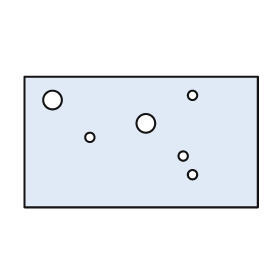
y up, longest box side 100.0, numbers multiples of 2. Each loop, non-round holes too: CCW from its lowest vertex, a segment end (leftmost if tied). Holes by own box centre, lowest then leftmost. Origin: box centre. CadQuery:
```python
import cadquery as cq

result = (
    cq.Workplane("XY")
    .moveTo(-50.0, -28.0)
    .lineTo(50.0, -28.0)
    .lineTo(50.0, 28.0)
    .lineTo(-50.0, 28.0)
    .close()
    .moveTo(22.0, -14.0)
    .circle(2.0)
    .moveTo(18.0, -6.0)
    .circle(2.0)
    .moveTo(-22.0, 2.0)
    .circle(2.0)
    .moveTo(2.0, 8.0)
    .circle(4.0)
    .moveTo(-38.0, 18.0)
    .circle(4.0)
    .moveTo(22.0, 20.0)
    .circle(2.0)
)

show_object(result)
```